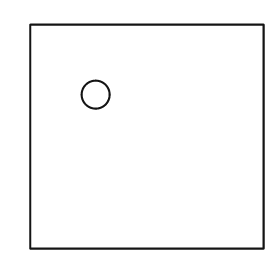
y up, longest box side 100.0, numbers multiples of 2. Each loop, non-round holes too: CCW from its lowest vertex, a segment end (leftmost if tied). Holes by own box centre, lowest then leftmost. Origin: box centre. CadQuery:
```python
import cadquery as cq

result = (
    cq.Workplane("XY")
    .moveTo(-50.0, -48.0)
    .lineTo(50.0, -48.0)
    .lineTo(50.0, 48.0)
    .lineTo(-50.0, 48.0)
    .close()
    .moveTo(-22.0, 18.0)
    .circle(6.0)
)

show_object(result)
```